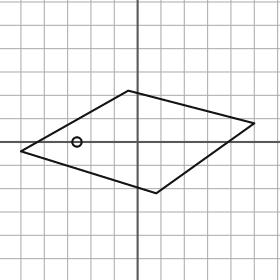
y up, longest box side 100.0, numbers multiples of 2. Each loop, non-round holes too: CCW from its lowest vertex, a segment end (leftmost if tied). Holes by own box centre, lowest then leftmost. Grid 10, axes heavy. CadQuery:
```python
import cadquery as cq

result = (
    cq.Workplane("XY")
    .moveTo(8.0, -22.0)
    .lineTo(50.0, 8.0)
    .lineTo(-4.0, 22.0)
    .lineTo(-50.0, -4.0)
    .close()
    .moveTo(-26.0, 0.0)
    .circle(2.0)
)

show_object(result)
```